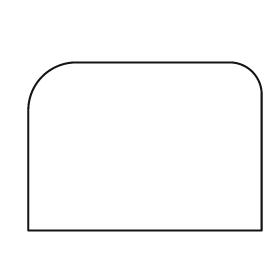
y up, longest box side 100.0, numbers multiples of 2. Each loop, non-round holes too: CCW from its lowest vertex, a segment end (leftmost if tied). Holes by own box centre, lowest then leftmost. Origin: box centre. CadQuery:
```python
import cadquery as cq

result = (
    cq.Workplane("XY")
    .moveTo(-50.0, -36.0)
    .lineTo(50.0, -36.0)
    .lineTo(50.0, 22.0)
    .threePointArc((46.0, 32.0), (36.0, 36.0))
    .lineTo(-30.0, 36.0)
    .threePointArc((-44.0, 30.0), (-50.0, 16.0))
    .close()
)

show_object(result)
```